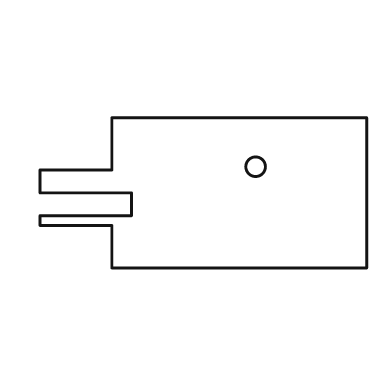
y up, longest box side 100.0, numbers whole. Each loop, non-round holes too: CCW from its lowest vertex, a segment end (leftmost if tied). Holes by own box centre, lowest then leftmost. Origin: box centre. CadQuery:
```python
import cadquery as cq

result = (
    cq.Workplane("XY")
    .moveTo(-28.0, -23.0)
    .lineTo(50.0, -23.0)
    .lineTo(50.0, 23.0)
    .lineTo(-28.0, 23.0)
    .lineTo(-28.0, 7.0)
    .lineTo(-50.0, 7.0)
    .lineTo(-50.0, 0.0)
    .lineTo(-22.0, 0.0)
    .lineTo(-22.0, -7.0)
    .lineTo(-50.0, -7.0)
    .lineTo(-50.0, -10.0)
    .lineTo(-28.0, -10.0)
    .close()
    .moveTo(16.0, 8.0)
    .circle(3.0)
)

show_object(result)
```